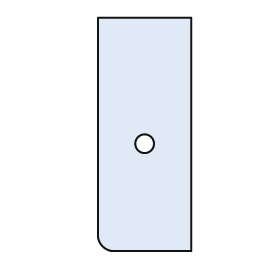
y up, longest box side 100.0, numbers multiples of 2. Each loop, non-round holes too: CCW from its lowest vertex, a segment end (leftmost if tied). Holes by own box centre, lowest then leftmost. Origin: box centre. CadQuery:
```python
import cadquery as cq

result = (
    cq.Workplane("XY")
    .moveTo(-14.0, -50.0)
    .lineTo(20.0, -50.0)
    .lineTo(20.0, 50.0)
    .lineTo(-20.0, 50.0)
    .lineTo(-20.0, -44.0)
    .threePointArc((-18.0, -48.0), (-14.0, -50.0))
    .close()
    .moveTo(0.0, -4.0)
    .circle(4.0)
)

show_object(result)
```